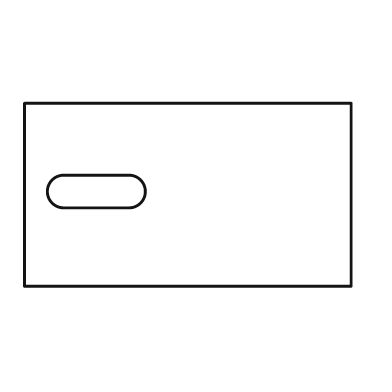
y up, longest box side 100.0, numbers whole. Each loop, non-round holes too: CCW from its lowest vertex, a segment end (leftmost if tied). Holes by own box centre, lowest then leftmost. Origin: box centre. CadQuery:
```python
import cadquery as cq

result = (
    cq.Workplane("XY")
    .moveTo(-50.0, -28.0)
    .lineTo(50.0, -28.0)
    .lineTo(50.0, 28.0)
    .lineTo(-50.0, 28.0)
    .close()
    .moveTo(-38.0, -4.0)
    .lineTo(-18.0, -4.0)
    .threePointArc((-13.0, 1.0), (-18.0, 6.0))
    .lineTo(-38.0, 6.0)
    .threePointArc((-43.0, 1.0), (-38.0, -4.0))
    .close()
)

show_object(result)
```